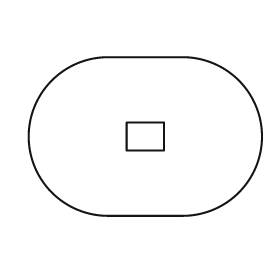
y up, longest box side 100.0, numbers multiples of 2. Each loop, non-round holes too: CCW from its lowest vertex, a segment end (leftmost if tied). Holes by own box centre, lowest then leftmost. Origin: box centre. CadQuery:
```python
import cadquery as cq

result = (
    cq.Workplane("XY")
    .moveTo(-16.0, -34.0)
    .lineTo(16.0, -34.0)
    .threePointArc((50.0, 0.0), (16.0, 34.0))
    .lineTo(-16.0, 34.0)
    .threePointArc((-50.0, 0.0), (-16.0, -34.0))
    .close()
    .moveTo(-8.0, -6.0)
    .lineTo(8.0, -6.0)
    .lineTo(8.0, 6.0)
    .lineTo(-8.0, 6.0)
    .close()
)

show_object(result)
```